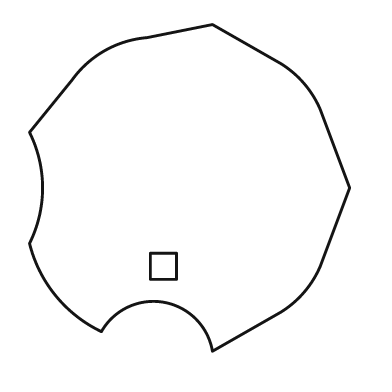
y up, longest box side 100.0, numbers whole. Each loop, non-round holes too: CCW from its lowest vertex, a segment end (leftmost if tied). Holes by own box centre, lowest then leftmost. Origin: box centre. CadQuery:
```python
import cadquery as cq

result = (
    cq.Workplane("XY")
    .moveTo(7.0, -50.0)
    .lineTo(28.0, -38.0)
    .threePointArc((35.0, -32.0), (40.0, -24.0))
    .lineTo(49.0, 0.0)
    .lineTo(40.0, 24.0)
    .threePointArc((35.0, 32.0), (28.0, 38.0))
    .lineTo(7.0, 50.0)
    .lineTo(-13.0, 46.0)
    .threePointArc((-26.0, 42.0), (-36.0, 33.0))
    .lineTo(-49.0, 17.0)
    .threePointArc((-45.0, 0.0), (-49.0, -17.0))
    .threePointArc((-41.0, -33.0), (-27.0, -44.0))
    .threePointArc((-8.0, -35.0), (7.0, -50.0))
    .close()
    .moveTo(-12.0, -28.0)
    .lineTo(-4.0, -28.0)
    .lineTo(-4.0, -20.0)
    .lineTo(-12.0, -20.0)
    .close()
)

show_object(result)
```